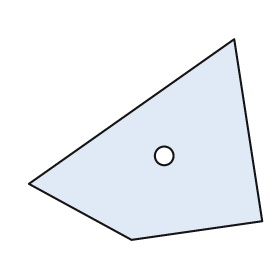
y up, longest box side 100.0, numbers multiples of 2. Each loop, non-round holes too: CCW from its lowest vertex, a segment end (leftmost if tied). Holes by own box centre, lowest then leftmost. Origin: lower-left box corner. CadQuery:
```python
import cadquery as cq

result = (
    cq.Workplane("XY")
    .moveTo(44.0, 0.0)
    .lineTo(100.0, 8.0)
    .lineTo(88.0, 86.0)
    .lineTo(0.0, 24.0)
    .close()
    .moveTo(58.0, 36.0)
    .circle(4.0)
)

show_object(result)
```